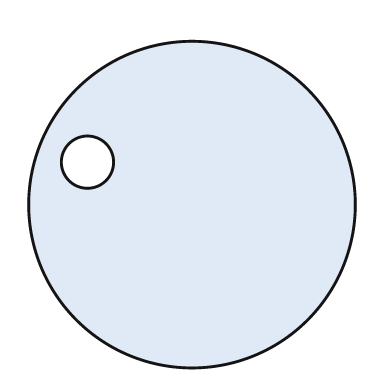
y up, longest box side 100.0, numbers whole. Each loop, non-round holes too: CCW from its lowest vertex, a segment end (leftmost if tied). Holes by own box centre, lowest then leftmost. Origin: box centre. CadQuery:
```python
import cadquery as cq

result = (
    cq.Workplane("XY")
    .moveTo(0.0, 0.0)
    .circle(50.0)
    .moveTo(-32.0, 13.0)
    .circle(8.0)
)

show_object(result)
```